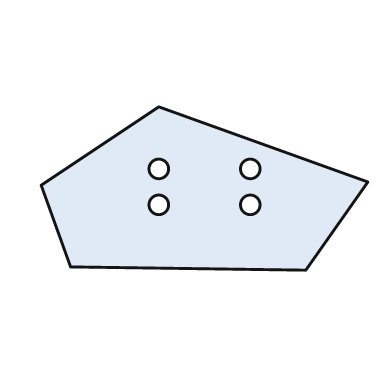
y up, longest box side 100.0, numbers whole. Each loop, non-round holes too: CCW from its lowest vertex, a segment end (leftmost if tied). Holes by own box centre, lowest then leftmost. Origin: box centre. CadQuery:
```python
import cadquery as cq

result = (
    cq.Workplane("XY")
    .moveTo(31.0, -25.0)
    .lineTo(50.0, 2.0)
    .lineTo(-14.0, 25.0)
    .lineTo(-50.0, 1.0)
    .lineTo(-41.0, -24.0)
    .close()
    .moveTo(-14.0, -5.0)
    .circle(3.0)
    .moveTo(14.0, -5.0)
    .circle(3.0)
    .moveTo(-14.0, 6.0)
    .circle(3.0)
    .moveTo(14.0, 6.0)
    .circle(3.0)
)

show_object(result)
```